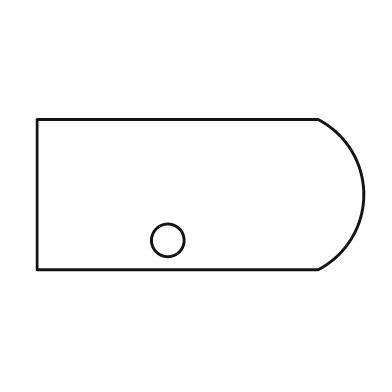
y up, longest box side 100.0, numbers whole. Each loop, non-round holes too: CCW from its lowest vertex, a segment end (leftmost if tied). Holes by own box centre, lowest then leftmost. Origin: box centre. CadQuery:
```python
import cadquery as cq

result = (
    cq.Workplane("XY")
    .moveTo(-50.0, -23.0)
    .lineTo(36.0, -23.0)
    .threePointArc((50.0, 0.0), (36.0, 23.0))
    .lineTo(-50.0, 23.0)
    .close()
    .moveTo(-10.0, -14.0)
    .circle(5.0)
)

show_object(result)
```